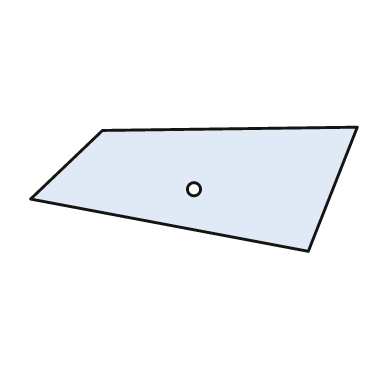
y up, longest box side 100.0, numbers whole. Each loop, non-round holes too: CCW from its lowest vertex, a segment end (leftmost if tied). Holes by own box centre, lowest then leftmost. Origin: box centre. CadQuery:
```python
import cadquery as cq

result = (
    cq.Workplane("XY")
    .moveTo(35.0, -19.0)
    .lineTo(50.0, 19.0)
    .lineTo(-28.0, 18.0)
    .lineTo(-50.0, -3.0)
    .close()
    .moveTo(0.0, 0.0)
    .circle(2.0)
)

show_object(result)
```